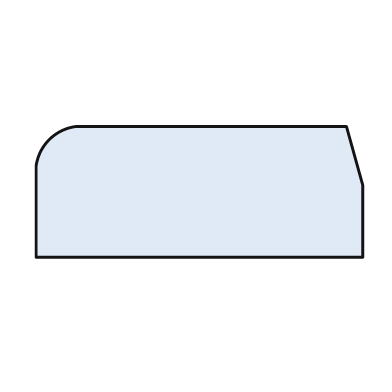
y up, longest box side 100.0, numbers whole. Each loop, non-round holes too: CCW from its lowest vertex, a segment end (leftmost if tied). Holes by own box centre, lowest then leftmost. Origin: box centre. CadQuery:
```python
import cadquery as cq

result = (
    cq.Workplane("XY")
    .moveTo(-50.0, -20.0)
    .lineTo(50.0, -20.0)
    .lineTo(50.0, 2.0)
    .lineTo(45.0, 20.0)
    .lineTo(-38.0, 20.0)
    .threePointArc((-46.0, 16.0), (-50.0, 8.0))
    .close()
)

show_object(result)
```